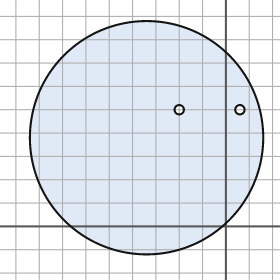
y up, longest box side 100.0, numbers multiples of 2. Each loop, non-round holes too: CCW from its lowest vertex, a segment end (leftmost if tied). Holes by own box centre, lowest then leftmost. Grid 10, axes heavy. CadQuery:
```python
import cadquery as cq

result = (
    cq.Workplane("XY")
    .moveTo(-34.0, 38.0)
    .circle(50.0)
    .moveTo(-20.0, 50.0)
    .circle(2.0)
    .moveTo(6.0, 50.0)
    .circle(2.0)
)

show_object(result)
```